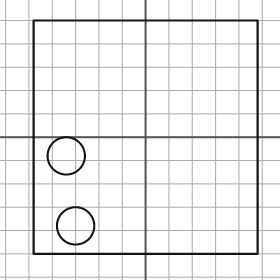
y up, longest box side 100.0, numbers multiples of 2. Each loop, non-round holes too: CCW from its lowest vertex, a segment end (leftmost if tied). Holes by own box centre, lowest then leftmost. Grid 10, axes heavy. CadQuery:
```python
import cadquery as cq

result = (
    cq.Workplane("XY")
    .moveTo(-48.0, -50.0)
    .lineTo(48.0, -50.0)
    .lineTo(48.0, 50.0)
    .lineTo(-48.0, 50.0)
    .close()
    .moveTo(-30.0, -38.0)
    .circle(8.0)
    .moveTo(-34.0, -8.0)
    .circle(8.0)
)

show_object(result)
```